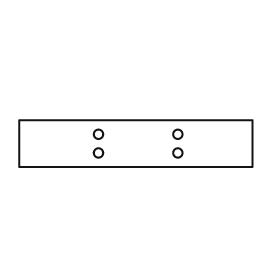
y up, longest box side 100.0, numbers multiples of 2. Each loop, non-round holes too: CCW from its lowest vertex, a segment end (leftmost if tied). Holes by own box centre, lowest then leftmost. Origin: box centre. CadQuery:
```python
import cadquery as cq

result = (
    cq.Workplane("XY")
    .moveTo(-50.0, -10.0)
    .lineTo(50.0, -10.0)
    .lineTo(50.0, 10.0)
    .lineTo(-50.0, 10.0)
    .close()
    .moveTo(-16.0, -4.0)
    .circle(2.0)
    .moveTo(18.0, -4.0)
    .circle(2.0)
    .moveTo(-16.0, 4.0)
    .circle(2.0)
    .moveTo(18.0, 4.0)
    .circle(2.0)
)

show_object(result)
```